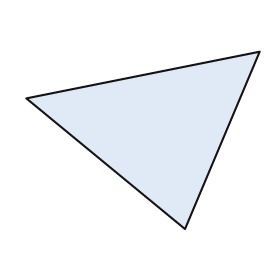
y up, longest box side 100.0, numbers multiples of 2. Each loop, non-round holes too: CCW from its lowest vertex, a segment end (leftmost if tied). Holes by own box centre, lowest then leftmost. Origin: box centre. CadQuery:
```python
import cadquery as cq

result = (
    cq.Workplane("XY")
    .moveTo(18.0, -38.0)
    .lineTo(50.0, 38.0)
    .lineTo(-50.0, 18.0)
    .close()
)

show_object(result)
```